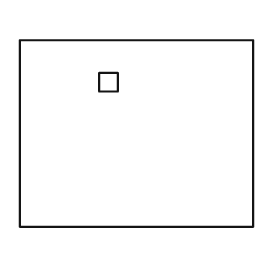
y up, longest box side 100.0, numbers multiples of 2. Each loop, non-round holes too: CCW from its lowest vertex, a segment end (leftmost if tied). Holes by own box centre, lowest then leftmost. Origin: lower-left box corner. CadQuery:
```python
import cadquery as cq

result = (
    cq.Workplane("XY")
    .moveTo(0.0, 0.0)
    .lineTo(100.0, 0.0)
    .lineTo(100.0, 80.0)
    .lineTo(0.0, 80.0)
    .close()
    .moveTo(34.0, 58.0)
    .lineTo(42.0, 58.0)
    .lineTo(42.0, 66.0)
    .lineTo(34.0, 66.0)
    .close()
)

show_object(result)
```